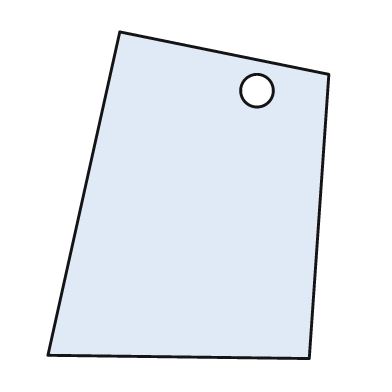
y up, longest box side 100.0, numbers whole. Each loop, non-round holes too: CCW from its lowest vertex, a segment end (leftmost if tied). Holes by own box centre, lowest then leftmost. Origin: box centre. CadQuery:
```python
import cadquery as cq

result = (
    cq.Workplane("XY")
    .moveTo(37.0, -50.0)
    .lineTo(43.0, 37.0)
    .lineTo(-21.0, 50.0)
    .lineTo(-43.0, -49.0)
    .close()
    .moveTo(21.0, 32.0)
    .circle(5.0)
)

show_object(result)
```